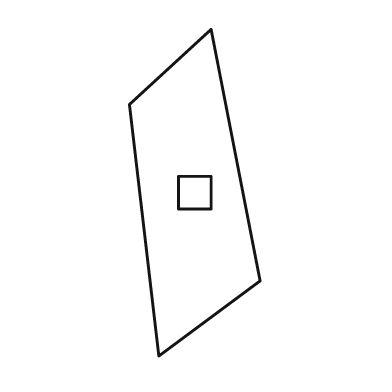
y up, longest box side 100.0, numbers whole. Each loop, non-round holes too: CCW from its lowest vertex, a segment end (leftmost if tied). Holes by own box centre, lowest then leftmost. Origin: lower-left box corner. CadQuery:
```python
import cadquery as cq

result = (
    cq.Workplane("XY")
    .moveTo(9.0, 0.0)
    .lineTo(40.0, 23.0)
    .lineTo(25.0, 100.0)
    .lineTo(0.0, 77.0)
    .close()
    .moveTo(15.0, 45.0)
    .lineTo(25.0, 45.0)
    .lineTo(25.0, 55.0)
    .lineTo(15.0, 55.0)
    .close()
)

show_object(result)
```